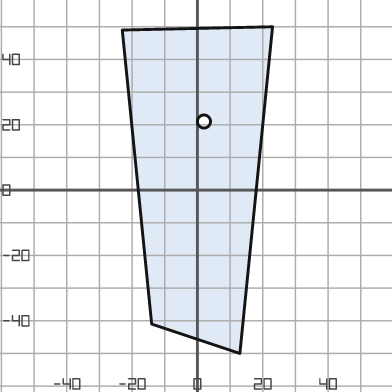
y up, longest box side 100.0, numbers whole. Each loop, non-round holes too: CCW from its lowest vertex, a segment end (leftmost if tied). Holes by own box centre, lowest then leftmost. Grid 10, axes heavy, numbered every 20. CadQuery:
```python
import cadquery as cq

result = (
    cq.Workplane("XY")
    .moveTo(13.0, -50.0)
    .lineTo(23.0, 50.0)
    .lineTo(-23.0, 49.0)
    .lineTo(-14.0, -41.0)
    .close()
    .moveTo(2.0, 21.0)
    .circle(2.0)
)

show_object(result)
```